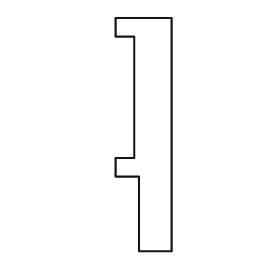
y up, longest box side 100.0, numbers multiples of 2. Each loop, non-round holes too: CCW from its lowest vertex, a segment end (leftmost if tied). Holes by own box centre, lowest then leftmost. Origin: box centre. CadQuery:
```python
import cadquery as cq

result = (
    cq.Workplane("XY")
    .moveTo(-2.0, -50.0)
    .lineTo(12.0, -50.0)
    .lineTo(12.0, 50.0)
    .lineTo(-12.0, 50.0)
    .lineTo(-12.0, 42.0)
    .lineTo(-4.0, 42.0)
    .lineTo(-4.0, -10.0)
    .lineTo(-12.0, -10.0)
    .lineTo(-12.0, -18.0)
    .lineTo(-2.0, -18.0)
    .close()
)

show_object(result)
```